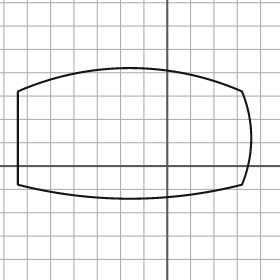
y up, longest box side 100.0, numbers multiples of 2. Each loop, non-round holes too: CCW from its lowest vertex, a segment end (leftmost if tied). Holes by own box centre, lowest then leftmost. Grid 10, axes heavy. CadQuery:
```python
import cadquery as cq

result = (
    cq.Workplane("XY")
    .moveTo(-64.0, -8.0)
    .threePointArc((-16.0, -14.0), (32.0, -8.0))
    .threePointArc((36.0, 12.0), (32.0, 32.0))
    .threePointArc((-16.0, 42.0), (-64.0, 32.0))
    .close()
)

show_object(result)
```